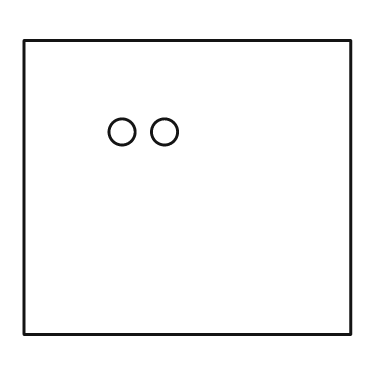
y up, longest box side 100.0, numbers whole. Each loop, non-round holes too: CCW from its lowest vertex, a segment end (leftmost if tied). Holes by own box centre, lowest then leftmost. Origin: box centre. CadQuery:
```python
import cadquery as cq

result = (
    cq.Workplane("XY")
    .moveTo(-50.0, -45.0)
    .lineTo(50.0, -45.0)
    .lineTo(50.0, 45.0)
    .lineTo(-50.0, 45.0)
    .close()
    .moveTo(-20.0, 17.0)
    .circle(4.0)
    .moveTo(-7.0, 17.0)
    .circle(4.0)
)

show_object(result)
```